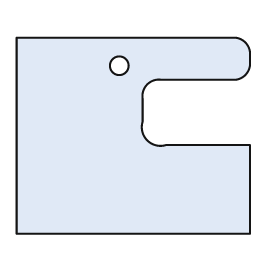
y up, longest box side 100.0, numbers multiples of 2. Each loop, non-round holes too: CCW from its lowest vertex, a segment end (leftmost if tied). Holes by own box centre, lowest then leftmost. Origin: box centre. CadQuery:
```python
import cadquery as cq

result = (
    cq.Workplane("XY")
    .moveTo(-50.0, -42.0)
    .lineTo(50.0, -42.0)
    .lineTo(50.0, -4.0)
    .lineTo(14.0, -4.0)
    .threePointArc((6.0, -2.0), (4.0, 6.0))
    .lineTo(4.0, 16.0)
    .threePointArc((6.0, 22.0), (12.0, 24.0))
    .lineTo(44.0, 24.0)
    .threePointArc((48.0, 26.0), (50.0, 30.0))
    .lineTo(50.0, 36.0)
    .threePointArc((48.0, 40.0), (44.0, 42.0))
    .lineTo(-50.0, 42.0)
    .close()
    .moveTo(-6.0, 30.0)
    .circle(4.0)
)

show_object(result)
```